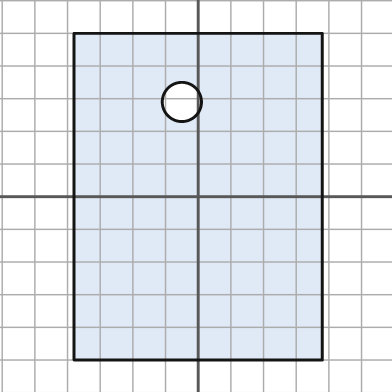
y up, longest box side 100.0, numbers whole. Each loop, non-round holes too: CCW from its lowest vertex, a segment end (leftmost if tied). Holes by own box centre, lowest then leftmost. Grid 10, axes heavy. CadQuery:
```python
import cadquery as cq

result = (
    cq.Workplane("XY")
    .moveTo(-38.0, -50.0)
    .lineTo(38.0, -50.0)
    .lineTo(38.0, 50.0)
    .lineTo(-38.0, 50.0)
    .close()
    .moveTo(-5.0, 29.0)
    .circle(6.0)
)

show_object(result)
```